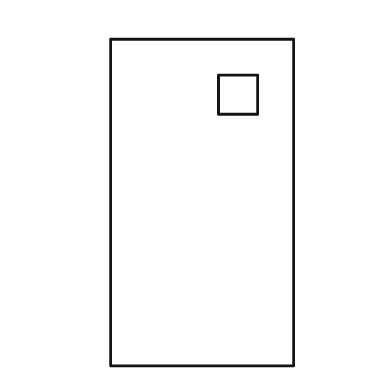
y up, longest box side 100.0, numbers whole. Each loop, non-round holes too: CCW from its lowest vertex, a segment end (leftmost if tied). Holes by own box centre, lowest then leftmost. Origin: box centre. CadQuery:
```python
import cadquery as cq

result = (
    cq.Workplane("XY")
    .moveTo(-28.0, -50.0)
    .lineTo(28.0, -50.0)
    .lineTo(28.0, 50.0)
    .lineTo(-28.0, 50.0)
    .close()
    .moveTo(5.0, 27.0)
    .lineTo(17.0, 27.0)
    .lineTo(17.0, 39.0)
    .lineTo(5.0, 39.0)
    .close()
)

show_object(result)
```